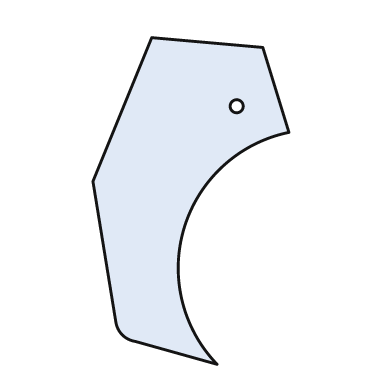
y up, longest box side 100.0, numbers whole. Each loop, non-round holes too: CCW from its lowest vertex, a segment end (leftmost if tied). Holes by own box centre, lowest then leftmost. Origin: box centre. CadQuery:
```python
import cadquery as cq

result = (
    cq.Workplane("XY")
    .moveTo(8.0, -50.0)
    .threePointArc((-2.0, -8.0), (30.0, 21.0))
    .lineTo(22.0, 47.0)
    .lineTo(-12.0, 50.0)
    .lineTo(-30.0, 6.0)
    .lineTo(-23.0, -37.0)
    .threePointArc((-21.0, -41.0), (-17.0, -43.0))
    .close()
    .moveTo(14.0, 29.0)
    .circle(2.0)
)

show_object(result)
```